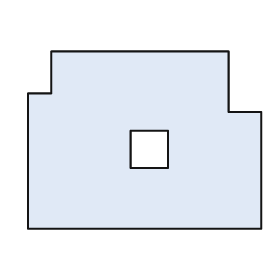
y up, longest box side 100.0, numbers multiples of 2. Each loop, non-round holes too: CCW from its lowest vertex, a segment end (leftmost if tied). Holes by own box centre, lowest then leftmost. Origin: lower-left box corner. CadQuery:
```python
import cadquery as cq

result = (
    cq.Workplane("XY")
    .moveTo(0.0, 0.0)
    .lineTo(100.0, 0.0)
    .lineTo(100.0, 50.0)
    .lineTo(86.0, 50.0)
    .lineTo(86.0, 76.0)
    .lineTo(10.0, 76.0)
    .lineTo(10.0, 58.0)
    .lineTo(0.0, 58.0)
    .close()
    .moveTo(44.0, 26.0)
    .lineTo(60.0, 26.0)
    .lineTo(60.0, 42.0)
    .lineTo(44.0, 42.0)
    .close()
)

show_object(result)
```